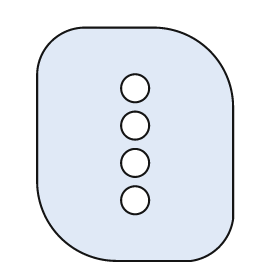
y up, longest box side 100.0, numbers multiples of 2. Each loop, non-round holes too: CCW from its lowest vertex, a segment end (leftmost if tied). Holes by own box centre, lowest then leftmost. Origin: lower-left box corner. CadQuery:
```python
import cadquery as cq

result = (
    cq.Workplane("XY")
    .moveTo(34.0, 0.0)
    .lineTo(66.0, 0.0)
    .threePointArc((78.0, 6.0), (84.0, 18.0))
    .lineTo(84.0, 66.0)
    .threePointArc((74.0, 90.0), (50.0, 100.0))
    .lineTo(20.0, 100.0)
    .threePointArc((6.0, 94.0), (0.0, 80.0))
    .lineTo(0.0, 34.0)
    .threePointArc((10.0, 10.0), (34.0, 0.0))
    .close()
    .moveTo(42.0, 26.0)
    .circle(6.0)
    .moveTo(42.0, 42.0)
    .circle(6.0)
    .moveTo(42.0, 58.0)
    .circle(6.0)
    .moveTo(42.0, 74.0)
    .circle(6.0)
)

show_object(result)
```